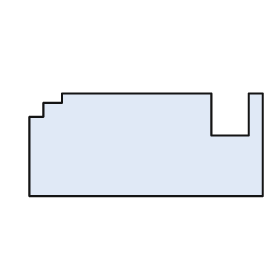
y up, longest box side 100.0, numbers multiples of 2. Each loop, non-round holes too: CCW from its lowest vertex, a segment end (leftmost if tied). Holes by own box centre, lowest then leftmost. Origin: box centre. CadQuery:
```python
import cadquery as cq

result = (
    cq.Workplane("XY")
    .moveTo(-50.0, -22.0)
    .lineTo(50.0, -22.0)
    .lineTo(50.0, 22.0)
    .lineTo(44.0, 22.0)
    .lineTo(44.0, 4.0)
    .lineTo(28.0, 4.0)
    .lineTo(28.0, 22.0)
    .lineTo(-36.0, 22.0)
    .lineTo(-36.0, 18.0)
    .lineTo(-44.0, 18.0)
    .lineTo(-44.0, 12.0)
    .lineTo(-50.0, 12.0)
    .close()
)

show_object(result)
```